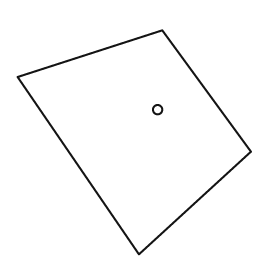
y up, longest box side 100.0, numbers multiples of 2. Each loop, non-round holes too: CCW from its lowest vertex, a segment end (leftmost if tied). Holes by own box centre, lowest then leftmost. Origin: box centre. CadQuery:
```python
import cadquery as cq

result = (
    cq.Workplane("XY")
    .moveTo(2.0, -48.0)
    .lineTo(50.0, -4.0)
    .lineTo(12.0, 48.0)
    .lineTo(-50.0, 28.0)
    .close()
    .moveTo(10.0, 14.0)
    .circle(2.0)
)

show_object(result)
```